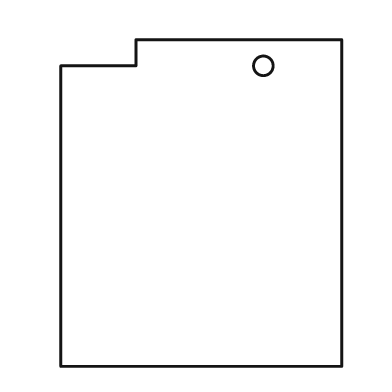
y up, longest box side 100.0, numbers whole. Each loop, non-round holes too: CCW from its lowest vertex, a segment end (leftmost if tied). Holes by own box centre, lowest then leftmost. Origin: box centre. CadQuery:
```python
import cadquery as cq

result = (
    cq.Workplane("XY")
    .moveTo(-43.0, -50.0)
    .lineTo(43.0, -50.0)
    .lineTo(43.0, 50.0)
    .lineTo(-20.0, 50.0)
    .lineTo(-20.0, 42.0)
    .lineTo(-43.0, 42.0)
    .close()
    .moveTo(19.0, 42.0)
    .circle(3.0)
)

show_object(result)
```